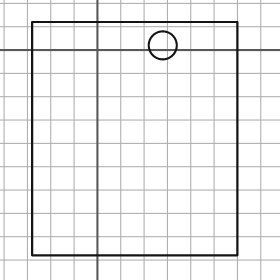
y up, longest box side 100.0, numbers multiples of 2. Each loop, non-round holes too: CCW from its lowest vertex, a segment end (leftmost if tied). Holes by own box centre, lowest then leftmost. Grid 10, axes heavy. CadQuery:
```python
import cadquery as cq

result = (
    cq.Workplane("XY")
    .moveTo(-28.0, -88.0)
    .lineTo(60.0, -88.0)
    .lineTo(60.0, 12.0)
    .lineTo(-28.0, 12.0)
    .close()
    .moveTo(28.0, 2.0)
    .circle(6.0)
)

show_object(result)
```